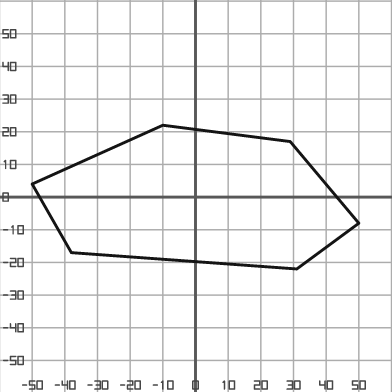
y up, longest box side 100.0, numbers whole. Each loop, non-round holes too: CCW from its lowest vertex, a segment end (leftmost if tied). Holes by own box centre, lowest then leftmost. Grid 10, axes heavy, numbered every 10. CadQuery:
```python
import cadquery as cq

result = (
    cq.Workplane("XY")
    .moveTo(31.0, -22.0)
    .lineTo(50.0, -8.0)
    .lineTo(29.0, 17.0)
    .lineTo(-10.0, 22.0)
    .lineTo(-50.0, 4.0)
    .lineTo(-38.0, -17.0)
    .close()
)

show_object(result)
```